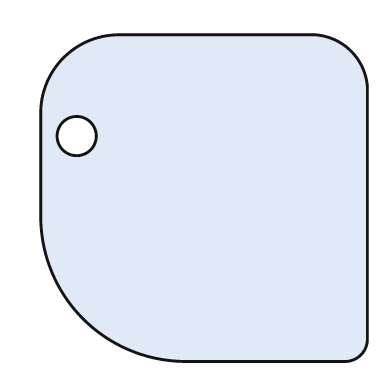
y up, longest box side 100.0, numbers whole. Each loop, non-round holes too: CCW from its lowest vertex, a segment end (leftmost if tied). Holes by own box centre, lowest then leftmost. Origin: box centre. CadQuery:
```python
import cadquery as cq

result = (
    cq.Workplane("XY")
    .moveTo(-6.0, -50.0)
    .lineTo(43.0, -50.0)
    .threePointArc((48.0, -48.0), (50.0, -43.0))
    .lineTo(50.0, 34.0)
    .threePointArc((45.0, 45.0), (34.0, 50.0))
    .lineTo(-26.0, 50.0)
    .threePointArc((-43.0, 43.0), (-50.0, 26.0))
    .lineTo(-50.0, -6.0)
    .threePointArc((-37.0, -37.0), (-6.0, -50.0))
    .close()
    .moveTo(-39.0, 19.0)
    .circle(6.0)
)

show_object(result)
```